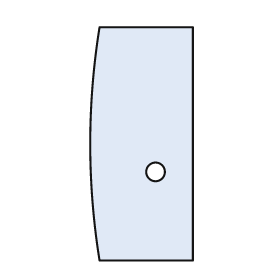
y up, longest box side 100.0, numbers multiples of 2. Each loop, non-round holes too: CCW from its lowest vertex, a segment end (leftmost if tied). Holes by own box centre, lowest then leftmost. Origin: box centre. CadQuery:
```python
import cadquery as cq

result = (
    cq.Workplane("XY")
    .moveTo(-18.0, -50.0)
    .lineTo(22.0, -50.0)
    .lineTo(22.0, 50.0)
    .lineTo(-18.0, 50.0)
    .threePointArc((-22.0, 0.0), (-18.0, -50.0))
    .close()
    .moveTo(6.0, -12.0)
    .circle(4.0)
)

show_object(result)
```